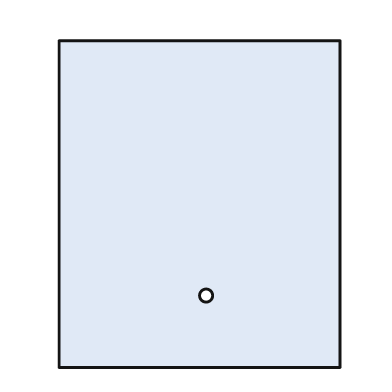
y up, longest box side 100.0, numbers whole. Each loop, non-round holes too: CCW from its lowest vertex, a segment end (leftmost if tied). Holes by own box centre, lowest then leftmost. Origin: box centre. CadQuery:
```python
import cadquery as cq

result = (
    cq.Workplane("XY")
    .moveTo(-43.0, -50.0)
    .lineTo(43.0, -50.0)
    .lineTo(43.0, 50.0)
    .lineTo(-43.0, 50.0)
    .close()
    .moveTo(2.0, -28.0)
    .circle(2.0)
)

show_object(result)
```